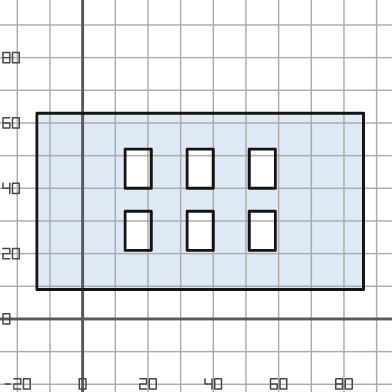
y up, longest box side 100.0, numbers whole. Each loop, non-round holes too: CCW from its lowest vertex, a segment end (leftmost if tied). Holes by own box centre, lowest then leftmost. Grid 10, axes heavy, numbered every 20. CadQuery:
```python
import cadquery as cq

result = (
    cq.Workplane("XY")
    .moveTo(-14.0, 9.0)
    .lineTo(86.0, 9.0)
    .lineTo(86.0, 63.0)
    .lineTo(-14.0, 63.0)
    .close()
    .moveTo(13.0, 21.0)
    .lineTo(21.0, 21.0)
    .lineTo(21.0, 33.0)
    .lineTo(13.0, 33.0)
    .close()
    .moveTo(32.0, 21.0)
    .lineTo(40.0, 21.0)
    .lineTo(40.0, 33.0)
    .lineTo(32.0, 33.0)
    .close()
    .moveTo(51.0, 21.0)
    .lineTo(59.0, 21.0)
    .lineTo(59.0, 33.0)
    .lineTo(51.0, 33.0)
    .close()
    .moveTo(13.0, 40.0)
    .lineTo(21.0, 40.0)
    .lineTo(21.0, 52.0)
    .lineTo(13.0, 52.0)
    .close()
    .moveTo(32.0, 40.0)
    .lineTo(40.0, 40.0)
    .lineTo(40.0, 52.0)
    .lineTo(32.0, 52.0)
    .close()
    .moveTo(51.0, 40.0)
    .lineTo(59.0, 40.0)
    .lineTo(59.0, 52.0)
    .lineTo(51.0, 52.0)
    .close()
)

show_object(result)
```